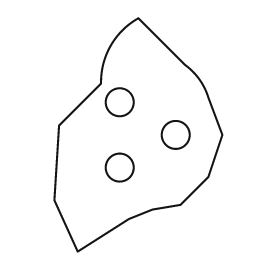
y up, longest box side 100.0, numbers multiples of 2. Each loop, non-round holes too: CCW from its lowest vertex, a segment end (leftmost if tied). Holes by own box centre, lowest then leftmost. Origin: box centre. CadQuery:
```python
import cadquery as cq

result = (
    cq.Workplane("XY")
    .moveTo(-26.0, -50.0)
    .lineTo(-4.0, -36.0)
    .lineTo(6.0, -32.0)
    .lineTo(18.0, -30.0)
    .lineTo(30.0, -18.0)
    .lineTo(36.0, 0.0)
    .lineTo(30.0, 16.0)
    .threePointArc((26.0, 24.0), (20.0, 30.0))
    .lineTo(0.0, 50.0)
    .threePointArc((-12.0, 38.0), (-16.0, 22.0))
    .lineTo(-34.0, 4.0)
    .lineTo(-36.0, -28.0)
    .close()
    .moveTo(-8.0, -14.0)
    .circle(6.0)
    .moveTo(16.0, 0.0)
    .circle(6.0)
    .moveTo(-8.0, 14.0)
    .circle(6.0)
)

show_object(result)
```